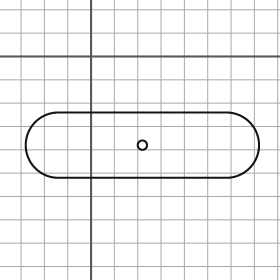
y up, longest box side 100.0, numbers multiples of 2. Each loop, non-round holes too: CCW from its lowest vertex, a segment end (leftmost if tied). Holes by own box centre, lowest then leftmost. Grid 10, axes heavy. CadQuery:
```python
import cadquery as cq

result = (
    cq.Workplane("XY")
    .moveTo(-14.0, -52.0)
    .lineTo(58.0, -52.0)
    .threePointArc((72.0, -38.0), (58.0, -24.0))
    .lineTo(-14.0, -24.0)
    .threePointArc((-28.0, -38.0), (-14.0, -52.0))
    .close()
    .moveTo(22.0, -38.0)
    .circle(2.0)
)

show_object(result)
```